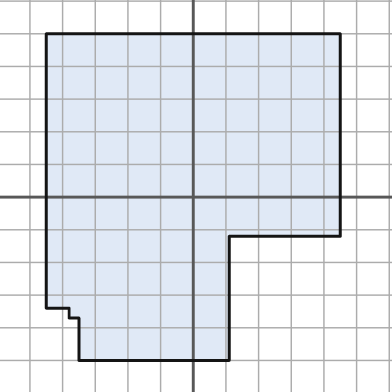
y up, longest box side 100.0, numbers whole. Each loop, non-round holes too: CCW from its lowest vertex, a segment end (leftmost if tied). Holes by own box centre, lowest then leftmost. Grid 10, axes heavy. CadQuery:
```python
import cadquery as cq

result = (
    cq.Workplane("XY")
    .moveTo(-35.0, -50.0)
    .lineTo(11.0, -50.0)
    .lineTo(11.0, -12.0)
    .lineTo(45.0, -12.0)
    .lineTo(45.0, 50.0)
    .lineTo(-45.0, 50.0)
    .lineTo(-45.0, -34.0)
    .lineTo(-38.0, -34.0)
    .lineTo(-38.0, -37.0)
    .lineTo(-35.0, -37.0)
    .close()
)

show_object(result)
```